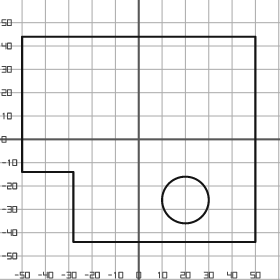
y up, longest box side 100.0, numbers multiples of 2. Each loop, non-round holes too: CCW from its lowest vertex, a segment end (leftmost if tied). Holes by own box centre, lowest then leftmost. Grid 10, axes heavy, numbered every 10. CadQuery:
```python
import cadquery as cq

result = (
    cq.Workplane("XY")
    .moveTo(-28.0, -44.0)
    .lineTo(50.0, -44.0)
    .lineTo(50.0, 44.0)
    .lineTo(-50.0, 44.0)
    .lineTo(-50.0, -14.0)
    .lineTo(-28.0, -14.0)
    .close()
    .moveTo(20.0, -26.0)
    .circle(10.0)
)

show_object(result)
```